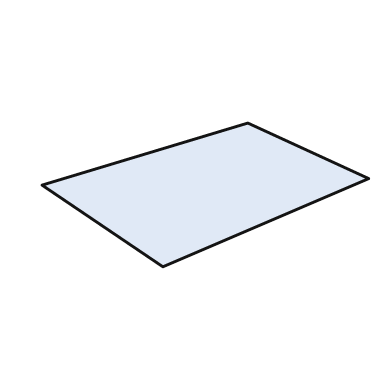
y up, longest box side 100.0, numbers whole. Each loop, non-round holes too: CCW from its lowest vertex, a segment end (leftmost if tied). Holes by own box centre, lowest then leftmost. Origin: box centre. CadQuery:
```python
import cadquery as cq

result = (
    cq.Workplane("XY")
    .moveTo(-13.0, -22.0)
    .lineTo(50.0, 5.0)
    .lineTo(13.0, 22.0)
    .lineTo(-50.0, 3.0)
    .close()
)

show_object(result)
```